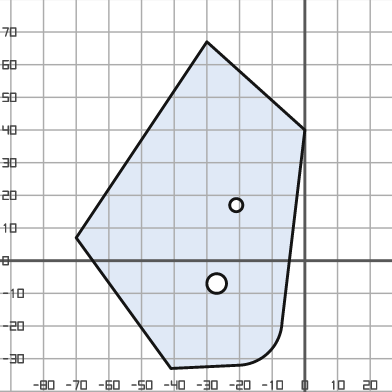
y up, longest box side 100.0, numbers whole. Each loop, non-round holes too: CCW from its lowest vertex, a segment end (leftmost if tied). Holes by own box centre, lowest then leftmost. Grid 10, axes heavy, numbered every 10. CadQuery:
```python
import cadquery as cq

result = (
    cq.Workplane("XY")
    .moveTo(-41.0, -33.0)
    .lineTo(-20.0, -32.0)
    .threePointArc((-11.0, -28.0), (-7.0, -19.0))
    .lineTo(0.0, 40.0)
    .lineTo(-30.0, 67.0)
    .lineTo(-70.0, 7.0)
    .close()
    .moveTo(-27.0, -7.0)
    .circle(3.0)
    .moveTo(-21.0, 17.0)
    .circle(2.0)
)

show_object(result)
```